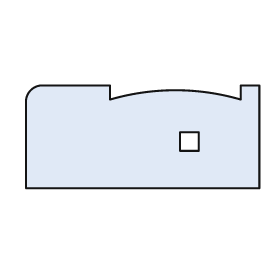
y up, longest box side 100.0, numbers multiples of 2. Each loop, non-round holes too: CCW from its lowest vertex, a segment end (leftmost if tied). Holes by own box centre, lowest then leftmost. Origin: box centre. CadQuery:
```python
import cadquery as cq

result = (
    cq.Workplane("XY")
    .moveTo(-50.0, -22.0)
    .lineTo(50.0, -22.0)
    .lineTo(50.0, 22.0)
    .lineTo(42.0, 22.0)
    .lineTo(42.0, 16.0)
    .threePointArc((14.0, 20.0), (-14.0, 16.0))
    .lineTo(-14.0, 22.0)
    .lineTo(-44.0, 22.0)
    .threePointArc((-48.0, 20.0), (-50.0, 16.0))
    .close()
    .moveTo(16.0, -6.0)
    .lineTo(24.0, -6.0)
    .lineTo(24.0, 2.0)
    .lineTo(16.0, 2.0)
    .close()
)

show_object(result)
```